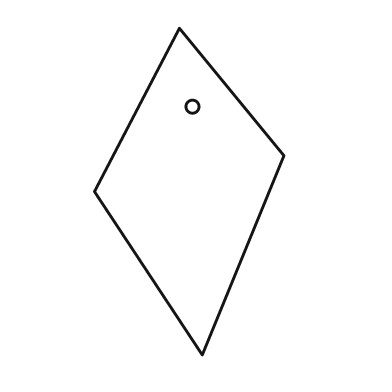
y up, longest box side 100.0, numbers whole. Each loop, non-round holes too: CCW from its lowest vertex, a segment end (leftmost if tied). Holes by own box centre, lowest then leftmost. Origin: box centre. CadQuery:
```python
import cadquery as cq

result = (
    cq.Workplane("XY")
    .moveTo(4.0, -50.0)
    .lineTo(29.0, 11.0)
    .lineTo(-3.0, 50.0)
    .lineTo(-29.0, 0.0)
    .close()
    .moveTo(1.0, 26.0)
    .circle(2.0)
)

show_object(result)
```